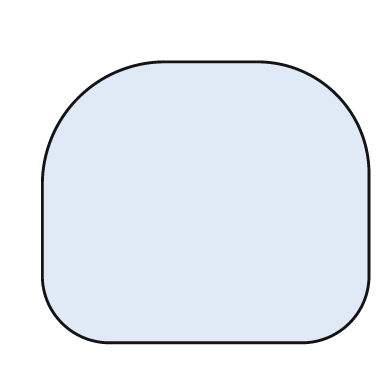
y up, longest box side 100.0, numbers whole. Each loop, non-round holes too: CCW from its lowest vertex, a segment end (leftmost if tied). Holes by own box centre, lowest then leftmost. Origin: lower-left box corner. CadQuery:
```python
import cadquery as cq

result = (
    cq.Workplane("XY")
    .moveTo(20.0, 0.0)
    .lineTo(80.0, 0.0)
    .threePointArc((94.0, 6.0), (100.0, 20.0))
    .lineTo(100.0, 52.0)
    .threePointArc((90.0, 76.0), (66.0, 86.0))
    .lineTo(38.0, 86.0)
    .threePointArc((11.0, 75.0), (0.0, 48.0))
    .lineTo(0.0, 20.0)
    .threePointArc((6.0, 6.0), (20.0, 0.0))
    .close()
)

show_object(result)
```